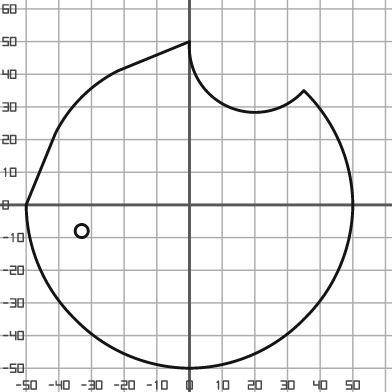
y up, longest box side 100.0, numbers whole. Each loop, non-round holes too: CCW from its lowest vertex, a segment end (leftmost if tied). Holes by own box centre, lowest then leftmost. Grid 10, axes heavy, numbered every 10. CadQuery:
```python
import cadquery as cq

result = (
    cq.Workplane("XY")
    .moveTo(0.0, -50.0)
    .threePointArc((19.0, -46.0), (35.0, -35.0))
    .threePointArc((46.0, -19.0), (50.0, 0.0))
    .threePointArc((46.0, 19.0), (35.0, 35.0))
    .threePointArc((12.0, 30.0), (0.0, 50.0))
    .lineTo(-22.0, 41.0)
    .threePointArc((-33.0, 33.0), (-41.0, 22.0))
    .lineTo(-50.0, 0.0)
    .threePointArc((-46.0, -19.0), (-35.0, -35.0))
    .threePointArc((-19.0, -46.0), (0.0, -50.0))
    .close()
    .moveTo(-33.0, -8.0)
    .circle(2.0)
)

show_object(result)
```